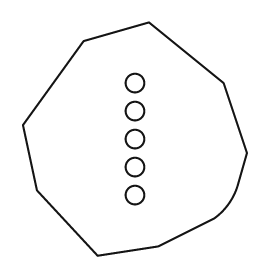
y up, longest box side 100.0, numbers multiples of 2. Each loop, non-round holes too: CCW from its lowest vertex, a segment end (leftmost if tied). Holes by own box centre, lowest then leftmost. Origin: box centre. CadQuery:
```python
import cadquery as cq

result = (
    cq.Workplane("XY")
    .moveTo(-16.0, -50.0)
    .lineTo(10.0, -46.0)
    .lineTo(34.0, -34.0)
    .threePointArc((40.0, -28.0), (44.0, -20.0))
    .lineTo(48.0, -6.0)
    .lineTo(38.0, 24.0)
    .lineTo(6.0, 50.0)
    .lineTo(-22.0, 42.0)
    .lineTo(-48.0, 6.0)
    .lineTo(-42.0, -22.0)
    .close()
    .moveTo(0.0, -24.0)
    .circle(4.0)
    .moveTo(0.0, -12.0)
    .circle(4.0)
    .moveTo(0.0, 0.0)
    .circle(4.0)
    .moveTo(0.0, 12.0)
    .circle(4.0)
    .moveTo(0.0, 24.0)
    .circle(4.0)
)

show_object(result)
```